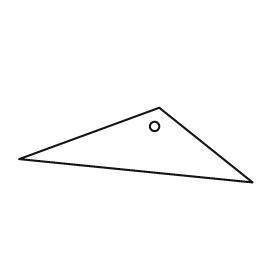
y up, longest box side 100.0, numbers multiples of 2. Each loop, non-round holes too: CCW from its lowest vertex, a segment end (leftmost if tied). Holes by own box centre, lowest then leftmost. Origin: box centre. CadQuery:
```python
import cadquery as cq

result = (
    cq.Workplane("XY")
    .moveTo(50.0, -16.0)
    .lineTo(10.0, 16.0)
    .lineTo(-50.0, -6.0)
    .close()
    .moveTo(8.0, 8.0)
    .circle(2.0)
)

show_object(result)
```